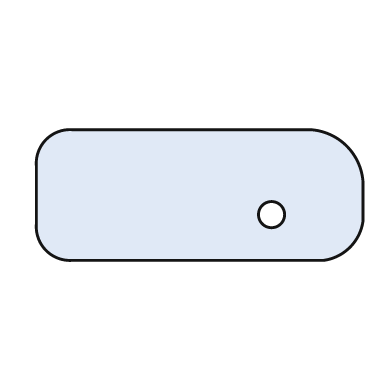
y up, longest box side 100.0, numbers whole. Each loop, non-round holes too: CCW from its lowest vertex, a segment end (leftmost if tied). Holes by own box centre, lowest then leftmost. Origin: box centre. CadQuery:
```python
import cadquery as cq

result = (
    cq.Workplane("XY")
    .moveTo(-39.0, -20.0)
    .lineTo(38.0, -20.0)
    .threePointArc((46.0, -16.0), (50.0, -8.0))
    .lineTo(50.0, 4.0)
    .threePointArc((45.0, 15.0), (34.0, 20.0))
    .lineTo(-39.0, 20.0)
    .threePointArc((-47.0, 17.0), (-50.0, 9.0))
    .lineTo(-50.0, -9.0)
    .threePointArc((-47.0, -17.0), (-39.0, -20.0))
    .close()
    .moveTo(22.0, -6.0)
    .circle(4.0)
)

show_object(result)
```